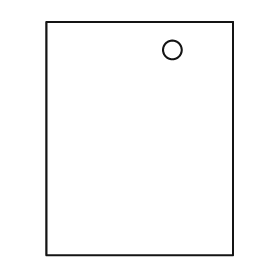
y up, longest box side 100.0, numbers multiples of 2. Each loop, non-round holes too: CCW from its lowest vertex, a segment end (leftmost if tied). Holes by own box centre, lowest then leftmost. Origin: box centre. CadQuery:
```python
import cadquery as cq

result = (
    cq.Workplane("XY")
    .moveTo(-40.0, -50.0)
    .lineTo(40.0, -50.0)
    .lineTo(40.0, 50.0)
    .lineTo(-40.0, 50.0)
    .close()
    .moveTo(14.0, 38.0)
    .circle(4.0)
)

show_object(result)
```